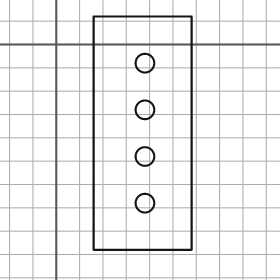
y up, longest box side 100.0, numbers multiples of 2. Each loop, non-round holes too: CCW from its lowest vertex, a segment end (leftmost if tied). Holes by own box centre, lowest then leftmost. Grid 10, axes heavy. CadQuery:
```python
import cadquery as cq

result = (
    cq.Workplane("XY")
    .moveTo(16.0, -88.0)
    .lineTo(58.0, -88.0)
    .lineTo(58.0, 12.0)
    .lineTo(16.0, 12.0)
    .close()
    .moveTo(38.0, -68.0)
    .circle(4.0)
    .moveTo(38.0, -48.0)
    .circle(4.0)
    .moveTo(38.0, -28.0)
    .circle(4.0)
    .moveTo(38.0, -8.0)
    .circle(4.0)
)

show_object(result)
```